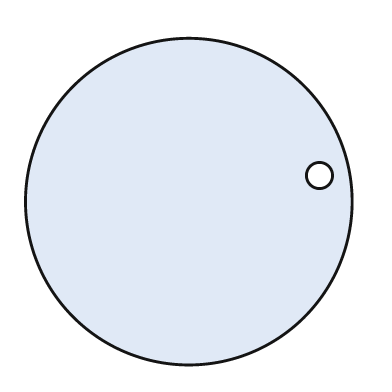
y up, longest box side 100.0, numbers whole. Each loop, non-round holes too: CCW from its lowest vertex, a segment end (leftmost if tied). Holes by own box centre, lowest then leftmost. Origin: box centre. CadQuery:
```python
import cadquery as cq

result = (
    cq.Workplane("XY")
    .moveTo(0.0, 0.0)
    .circle(50.0)
    .moveTo(40.0, 8.0)
    .circle(4.0)
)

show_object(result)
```